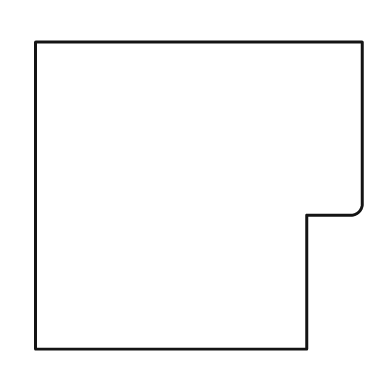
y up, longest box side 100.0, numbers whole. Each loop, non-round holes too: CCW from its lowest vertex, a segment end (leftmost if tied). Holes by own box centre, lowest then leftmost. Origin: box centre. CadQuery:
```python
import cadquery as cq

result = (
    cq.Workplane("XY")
    .moveTo(-50.0, -47.0)
    .lineTo(33.0, -47.0)
    .lineTo(33.0, -6.0)
    .lineTo(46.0, -6.0)
    .threePointArc((49.0, -5.0), (50.0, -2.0))
    .lineTo(50.0, 47.0)
    .lineTo(-50.0, 47.0)
    .close()
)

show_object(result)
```